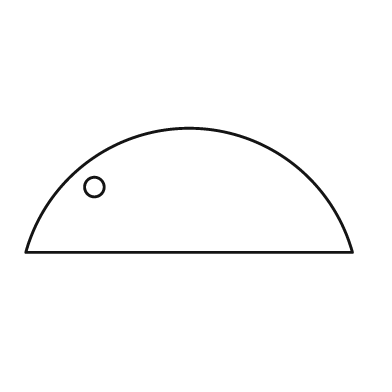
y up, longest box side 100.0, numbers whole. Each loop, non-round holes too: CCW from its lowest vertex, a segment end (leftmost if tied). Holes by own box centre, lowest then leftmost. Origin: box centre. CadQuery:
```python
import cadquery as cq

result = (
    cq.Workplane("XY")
    .moveTo(-50.0, -19.0)
    .lineTo(50.0, -19.0)
    .threePointArc((0.0, 19.0), (-50.0, -19.0))
    .close()
    .moveTo(-29.0, 1.0)
    .circle(3.0)
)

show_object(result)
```